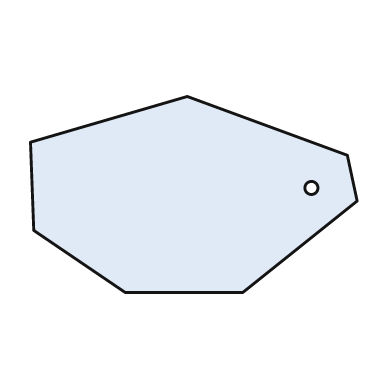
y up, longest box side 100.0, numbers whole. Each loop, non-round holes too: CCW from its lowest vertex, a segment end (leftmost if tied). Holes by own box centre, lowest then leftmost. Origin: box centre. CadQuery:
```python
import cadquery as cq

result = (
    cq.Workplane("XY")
    .moveTo(-21.0, -30.0)
    .lineTo(15.0, -30.0)
    .lineTo(50.0, -2.0)
    .lineTo(47.0, 12.0)
    .lineTo(-2.0, 30.0)
    .lineTo(-50.0, 16.0)
    .lineTo(-49.0, -11.0)
    .close()
    .moveTo(36.0, 2.0)
    .circle(2.0)
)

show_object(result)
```